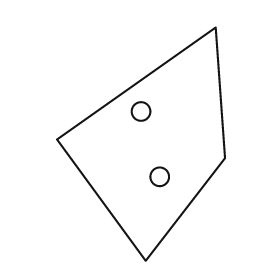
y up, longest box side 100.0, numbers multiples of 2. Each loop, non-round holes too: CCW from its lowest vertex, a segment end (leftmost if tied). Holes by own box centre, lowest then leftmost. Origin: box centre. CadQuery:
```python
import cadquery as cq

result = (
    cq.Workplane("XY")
    .moveTo(2.0, -50.0)
    .lineTo(36.0, -6.0)
    .lineTo(32.0, 50.0)
    .lineTo(-36.0, 2.0)
    .close()
    .moveTo(8.0, -14.0)
    .circle(4.0)
    .moveTo(0.0, 14.0)
    .circle(4.0)
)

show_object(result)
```